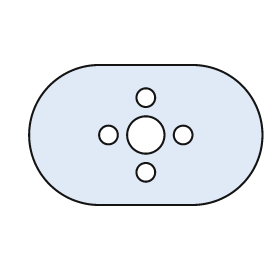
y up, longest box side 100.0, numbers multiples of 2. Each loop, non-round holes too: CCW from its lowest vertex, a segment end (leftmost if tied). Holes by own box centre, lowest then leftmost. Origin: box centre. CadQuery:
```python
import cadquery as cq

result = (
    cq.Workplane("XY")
    .moveTo(-20.0, -30.0)
    .lineTo(20.0, -30.0)
    .threePointArc((50.0, 0.0), (20.0, 30.0))
    .lineTo(-20.0, 30.0)
    .threePointArc((-50.0, 0.0), (-20.0, -30.0))
    .close()
    .moveTo(0.0, -16.0)
    .circle(4.0)
    .moveTo(-16.0, 0.0)
    .circle(4.0)
    .moveTo(0.0, 0.0)
    .circle(8.0)
    .moveTo(16.0, 0.0)
    .circle(4.0)
    .moveTo(0.0, 16.0)
    .circle(4.0)
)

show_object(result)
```